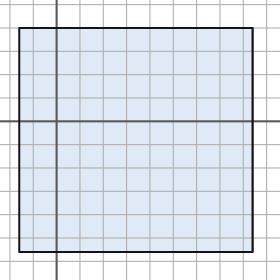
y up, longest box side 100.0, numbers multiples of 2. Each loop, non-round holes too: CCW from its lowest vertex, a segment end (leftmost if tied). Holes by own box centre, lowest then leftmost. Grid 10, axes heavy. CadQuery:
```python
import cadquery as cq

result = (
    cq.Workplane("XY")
    .moveTo(-16.0, -56.0)
    .lineTo(84.0, -56.0)
    .lineTo(84.0, 40.0)
    .lineTo(-16.0, 40.0)
    .close()
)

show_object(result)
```